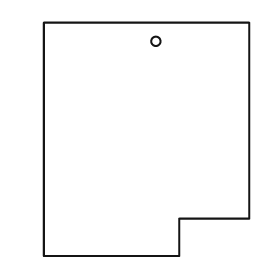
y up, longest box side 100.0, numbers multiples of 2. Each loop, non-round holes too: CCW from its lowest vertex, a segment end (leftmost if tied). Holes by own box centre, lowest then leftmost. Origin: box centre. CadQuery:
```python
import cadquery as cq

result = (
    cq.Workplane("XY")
    .moveTo(-44.0, -50.0)
    .lineTo(14.0, -50.0)
    .lineTo(14.0, -34.0)
    .lineTo(44.0, -34.0)
    .lineTo(44.0, 50.0)
    .lineTo(-44.0, 50.0)
    .close()
    .moveTo(4.0, 42.0)
    .circle(2.0)
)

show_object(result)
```